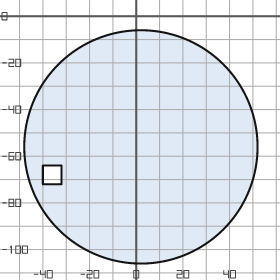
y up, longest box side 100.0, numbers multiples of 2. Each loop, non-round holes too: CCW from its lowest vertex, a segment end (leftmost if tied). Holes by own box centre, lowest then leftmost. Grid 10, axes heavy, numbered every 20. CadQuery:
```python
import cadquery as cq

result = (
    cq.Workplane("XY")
    .moveTo(2.0, -56.0)
    .circle(50.0)
    .moveTo(-40.0, -72.0)
    .lineTo(-32.0, -72.0)
    .lineTo(-32.0, -64.0)
    .lineTo(-40.0, -64.0)
    .close()
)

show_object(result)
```